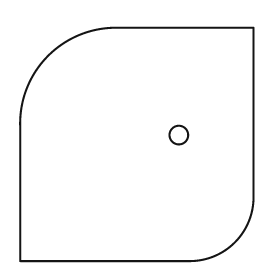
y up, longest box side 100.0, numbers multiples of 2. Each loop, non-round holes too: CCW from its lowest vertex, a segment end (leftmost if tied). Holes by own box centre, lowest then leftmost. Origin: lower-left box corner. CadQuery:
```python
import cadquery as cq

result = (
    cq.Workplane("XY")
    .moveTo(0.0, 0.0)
    .lineTo(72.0, 0.0)
    .threePointArc((92.0, 8.0), (100.0, 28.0))
    .lineTo(100.0, 100.0)
    .lineTo(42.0, 100.0)
    .threePointArc((12.0, 88.0), (0.0, 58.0))
    .close()
    .moveTo(68.0, 54.0)
    .circle(4.0)
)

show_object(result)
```